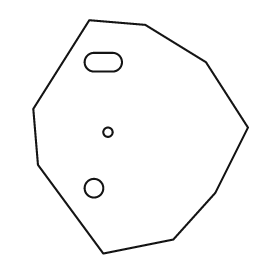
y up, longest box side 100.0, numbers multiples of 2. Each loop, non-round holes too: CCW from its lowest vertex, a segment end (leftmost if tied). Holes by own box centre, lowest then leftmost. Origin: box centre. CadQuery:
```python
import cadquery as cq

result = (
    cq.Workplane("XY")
    .moveTo(-16.0, -50.0)
    .lineTo(14.0, -44.0)
    .lineTo(32.0, -24.0)
    .lineTo(46.0, 4.0)
    .lineTo(28.0, 32.0)
    .lineTo(2.0, 48.0)
    .lineTo(-22.0, 50.0)
    .lineTo(-46.0, 12.0)
    .lineTo(-44.0, -12.0)
    .close()
    .moveTo(-20.0, -22.0)
    .circle(4.0)
    .moveTo(-14.0, 2.0)
    .circle(2.0)
    .moveTo(-20.0, 28.0)
    .lineTo(-12.0, 28.0)
    .threePointArc((-8.0, 32.0), (-12.0, 36.0))
    .lineTo(-20.0, 36.0)
    .threePointArc((-24.0, 32.0), (-20.0, 28.0))
    .close()
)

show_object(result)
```